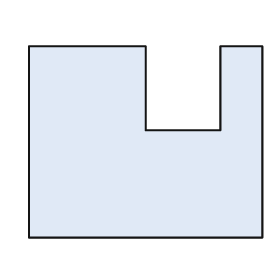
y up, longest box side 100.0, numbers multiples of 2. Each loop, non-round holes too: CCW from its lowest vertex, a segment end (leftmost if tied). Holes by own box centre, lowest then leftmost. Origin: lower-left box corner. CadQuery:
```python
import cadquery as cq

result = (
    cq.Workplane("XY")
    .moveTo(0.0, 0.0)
    .lineTo(100.0, 0.0)
    .lineTo(100.0, 82.0)
    .lineTo(82.0, 82.0)
    .lineTo(82.0, 46.0)
    .lineTo(50.0, 46.0)
    .lineTo(50.0, 82.0)
    .lineTo(0.0, 82.0)
    .close()
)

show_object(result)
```